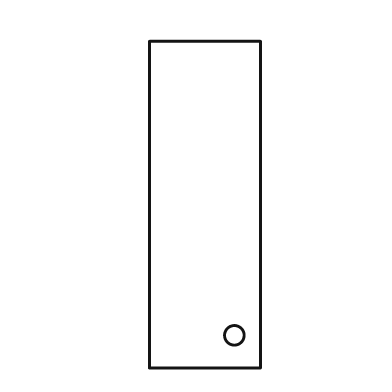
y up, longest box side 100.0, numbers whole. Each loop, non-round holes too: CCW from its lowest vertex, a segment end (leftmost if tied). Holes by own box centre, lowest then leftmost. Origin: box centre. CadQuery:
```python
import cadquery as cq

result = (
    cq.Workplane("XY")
    .moveTo(-17.0, -50.0)
    .lineTo(17.0, -50.0)
    .lineTo(17.0, 50.0)
    .lineTo(-17.0, 50.0)
    .close()
    .moveTo(9.0, -40.0)
    .circle(3.0)
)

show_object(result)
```